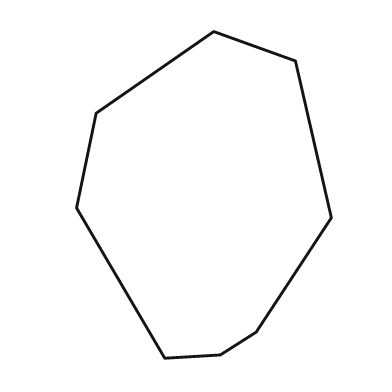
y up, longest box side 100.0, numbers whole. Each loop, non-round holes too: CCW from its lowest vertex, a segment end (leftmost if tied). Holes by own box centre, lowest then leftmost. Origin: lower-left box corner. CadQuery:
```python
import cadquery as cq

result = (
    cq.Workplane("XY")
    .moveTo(27.0, 0.0)
    .lineTo(44.0, 1.0)
    .lineTo(55.0, 8.0)
    .lineTo(78.0, 43.0)
    .lineTo(67.0, 91.0)
    .lineTo(42.0, 100.0)
    .lineTo(6.0, 75.0)
    .lineTo(0.0, 46.0)
    .close()
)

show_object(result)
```